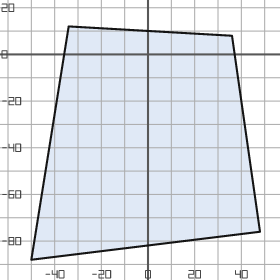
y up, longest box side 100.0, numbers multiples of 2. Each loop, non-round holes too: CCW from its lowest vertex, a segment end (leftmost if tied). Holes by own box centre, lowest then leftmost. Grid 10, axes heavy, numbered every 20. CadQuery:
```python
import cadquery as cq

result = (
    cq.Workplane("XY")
    .moveTo(-50.0, -88.0)
    .lineTo(48.0, -76.0)
    .lineTo(36.0, 8.0)
    .lineTo(-34.0, 12.0)
    .close()
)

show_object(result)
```